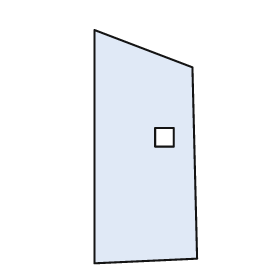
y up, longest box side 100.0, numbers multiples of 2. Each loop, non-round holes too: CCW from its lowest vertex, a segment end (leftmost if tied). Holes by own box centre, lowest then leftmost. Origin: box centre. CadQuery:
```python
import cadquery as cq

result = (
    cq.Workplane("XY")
    .moveTo(-22.0, -50.0)
    .lineTo(22.0, -48.0)
    .lineTo(20.0, 34.0)
    .lineTo(-22.0, 50.0)
    .close()
    .moveTo(4.0, 0.0)
    .lineTo(12.0, 0.0)
    .lineTo(12.0, 8.0)
    .lineTo(4.0, 8.0)
    .close()
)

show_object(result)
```